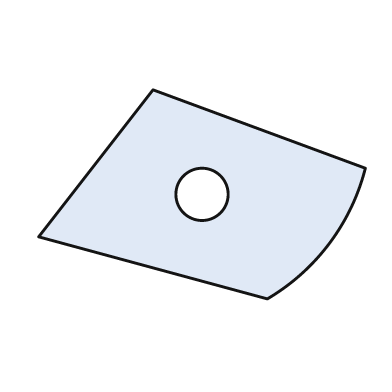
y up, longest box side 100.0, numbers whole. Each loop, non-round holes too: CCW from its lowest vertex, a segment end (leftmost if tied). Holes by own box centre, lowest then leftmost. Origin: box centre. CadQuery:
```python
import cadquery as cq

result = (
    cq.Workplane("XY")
    .moveTo(20.0, -32.0)
    .threePointArc((39.0, -15.0), (50.0, 8.0))
    .lineTo(-15.0, 32.0)
    .lineTo(-50.0, -13.0)
    .close()
    .moveTo(0.0, 0.0)
    .circle(8.0)
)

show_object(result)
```